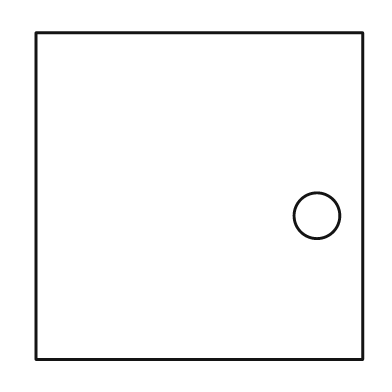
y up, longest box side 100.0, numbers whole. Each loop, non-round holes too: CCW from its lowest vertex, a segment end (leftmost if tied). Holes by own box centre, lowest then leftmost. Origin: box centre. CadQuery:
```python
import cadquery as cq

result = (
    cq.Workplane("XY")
    .moveTo(-50.0, -50.0)
    .lineTo(50.0, -50.0)
    .lineTo(50.0, 50.0)
    .lineTo(-50.0, 50.0)
    .close()
    .moveTo(36.0, -6.0)
    .circle(7.0)
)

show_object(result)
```